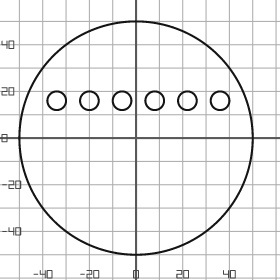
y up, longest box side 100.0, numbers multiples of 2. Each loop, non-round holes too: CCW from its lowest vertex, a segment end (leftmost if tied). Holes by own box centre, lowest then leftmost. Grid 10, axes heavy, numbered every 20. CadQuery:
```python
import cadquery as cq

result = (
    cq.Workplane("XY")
    .moveTo(0.0, 0.0)
    .circle(50.0)
    .moveTo(-34.0, 16.0)
    .circle(4.0)
    .moveTo(-20.0, 16.0)
    .circle(4.0)
    .moveTo(-6.0, 16.0)
    .circle(4.0)
    .moveTo(8.0, 16.0)
    .circle(4.0)
    .moveTo(22.0, 16.0)
    .circle(4.0)
    .moveTo(36.0, 16.0)
    .circle(4.0)
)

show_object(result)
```